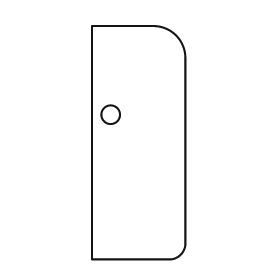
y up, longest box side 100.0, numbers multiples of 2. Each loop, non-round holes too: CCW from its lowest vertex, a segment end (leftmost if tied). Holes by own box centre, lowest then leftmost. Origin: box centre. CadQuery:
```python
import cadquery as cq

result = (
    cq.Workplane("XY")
    .moveTo(-20.0, -50.0)
    .lineTo(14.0, -50.0)
    .threePointArc((18.0, -48.0), (20.0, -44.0))
    .lineTo(20.0, 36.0)
    .threePointArc((16.0, 46.0), (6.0, 50.0))
    .lineTo(-20.0, 50.0)
    .close()
    .moveTo(-12.0, 12.0)
    .circle(4.0)
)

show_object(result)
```